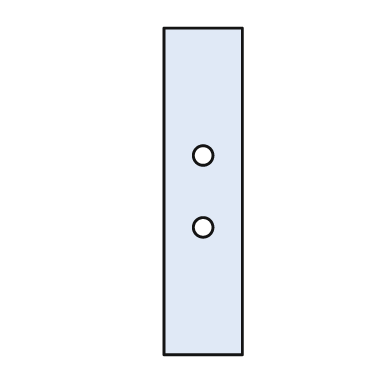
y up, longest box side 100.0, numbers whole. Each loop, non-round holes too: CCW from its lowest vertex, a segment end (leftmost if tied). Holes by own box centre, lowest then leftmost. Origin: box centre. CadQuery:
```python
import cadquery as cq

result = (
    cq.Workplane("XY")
    .moveTo(-12.0, -50.0)
    .lineTo(12.0, -50.0)
    .lineTo(12.0, 50.0)
    .lineTo(-12.0, 50.0)
    .close()
    .moveTo(0.0, -11.0)
    .circle(3.0)
    .moveTo(0.0, 11.0)
    .circle(3.0)
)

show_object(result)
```